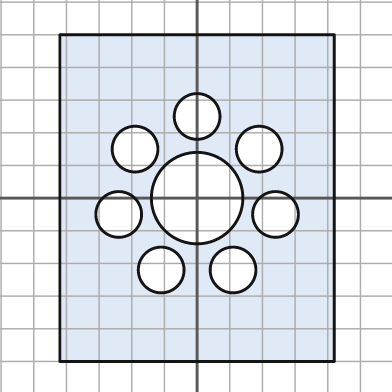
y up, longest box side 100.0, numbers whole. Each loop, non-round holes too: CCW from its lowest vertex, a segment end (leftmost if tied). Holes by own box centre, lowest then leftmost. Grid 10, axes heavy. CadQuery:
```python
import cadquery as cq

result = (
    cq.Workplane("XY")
    .moveTo(-42.0, -50.0)
    .lineTo(42.0, -50.0)
    .lineTo(42.0, 50.0)
    .lineTo(-42.0, 50.0)
    .close()
    .moveTo(-11.0, -22.0)
    .circle(7.0)
    .moveTo(11.0, -22.0)
    .circle(7.0)
    .moveTo(-24.0, -5.0)
    .circle(7.0)
    .moveTo(24.0, -5.0)
    .circle(7.0)
    .moveTo(0.0, 0.0)
    .circle(14.0)
    .moveTo(-19.0, 15.0)
    .circle(7.0)
    .moveTo(19.0, 15.0)
    .circle(7.0)
    .moveTo(0.0, 25.0)
    .circle(7.0)
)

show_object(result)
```